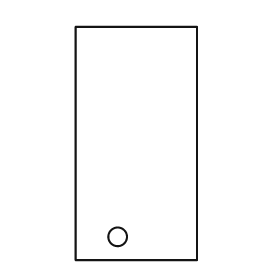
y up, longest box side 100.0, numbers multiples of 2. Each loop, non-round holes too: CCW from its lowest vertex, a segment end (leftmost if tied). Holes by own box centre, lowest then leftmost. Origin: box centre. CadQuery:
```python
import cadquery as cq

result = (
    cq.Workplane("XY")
    .moveTo(-26.0, -50.0)
    .lineTo(26.0, -50.0)
    .lineTo(26.0, 50.0)
    .lineTo(-26.0, 50.0)
    .close()
    .moveTo(-8.0, -40.0)
    .circle(4.0)
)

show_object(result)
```